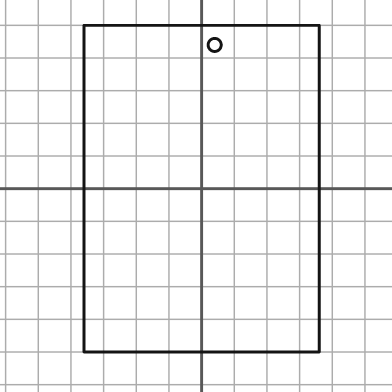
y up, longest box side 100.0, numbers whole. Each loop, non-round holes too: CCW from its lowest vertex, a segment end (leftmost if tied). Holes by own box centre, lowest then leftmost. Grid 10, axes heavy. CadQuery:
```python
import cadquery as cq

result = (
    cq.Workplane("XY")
    .moveTo(-36.0, -50.0)
    .lineTo(36.0, -50.0)
    .lineTo(36.0, 50.0)
    .lineTo(-36.0, 50.0)
    .close()
    .moveTo(4.0, 44.0)
    .circle(2.0)
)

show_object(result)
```